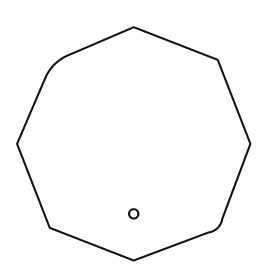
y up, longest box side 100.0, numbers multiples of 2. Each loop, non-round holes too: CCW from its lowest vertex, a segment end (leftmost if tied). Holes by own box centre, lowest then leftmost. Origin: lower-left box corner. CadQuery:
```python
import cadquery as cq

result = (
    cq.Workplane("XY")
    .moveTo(50.0, 0.0)
    .lineTo(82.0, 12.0)
    .threePointArc((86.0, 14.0), (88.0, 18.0))
    .lineTo(100.0, 50.0)
    .lineTo(86.0, 86.0)
    .lineTo(50.0, 100.0)
    .lineTo(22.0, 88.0)
    .threePointArc((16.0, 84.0), (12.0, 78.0))
    .lineTo(0.0, 50.0)
    .lineTo(14.0, 14.0)
    .close()
    .moveTo(50.0, 20.0)
    .circle(2.0)
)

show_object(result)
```